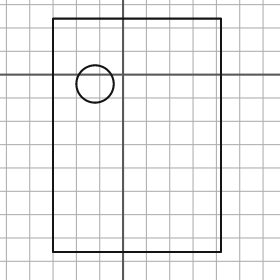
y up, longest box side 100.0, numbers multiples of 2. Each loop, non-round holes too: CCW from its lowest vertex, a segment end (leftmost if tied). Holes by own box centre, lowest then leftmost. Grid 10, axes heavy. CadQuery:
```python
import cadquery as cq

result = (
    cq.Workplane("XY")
    .moveTo(-30.0, -76.0)
    .lineTo(42.0, -76.0)
    .lineTo(42.0, 24.0)
    .lineTo(-30.0, 24.0)
    .close()
    .moveTo(-12.0, -4.0)
    .circle(8.0)
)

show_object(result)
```